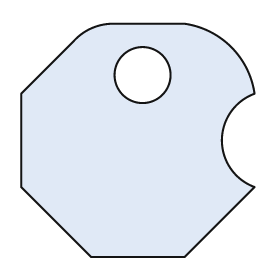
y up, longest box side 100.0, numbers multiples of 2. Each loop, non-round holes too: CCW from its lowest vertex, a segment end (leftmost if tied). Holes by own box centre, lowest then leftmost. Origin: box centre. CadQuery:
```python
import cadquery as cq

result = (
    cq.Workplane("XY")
    .moveTo(-20.0, -50.0)
    .lineTo(20.0, -50.0)
    .lineTo(50.0, -20.0)
    .threePointArc((36.0, 0.0), (50.0, 20.0))
    .threePointArc((40.0, 40.0), (20.0, 50.0))
    .lineTo(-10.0, 50.0)
    .threePointArc((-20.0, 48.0), (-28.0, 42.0))
    .lineTo(-50.0, 20.0)
    .lineTo(-50.0, -20.0)
    .close()
    .moveTo(2.0, 28.0)
    .circle(12.0)
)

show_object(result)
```